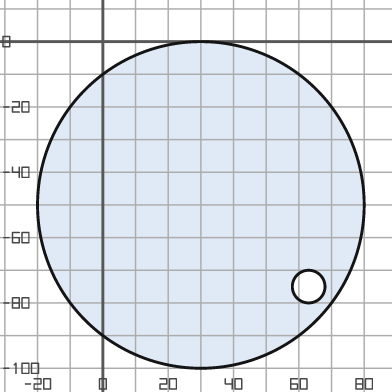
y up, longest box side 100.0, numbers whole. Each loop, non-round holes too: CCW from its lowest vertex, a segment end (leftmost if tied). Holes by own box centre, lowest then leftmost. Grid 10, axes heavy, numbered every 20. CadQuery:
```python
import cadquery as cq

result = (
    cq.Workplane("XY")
    .moveTo(30.0, -50.0)
    .circle(50.0)
    .moveTo(63.0, -75.0)
    .circle(5.0)
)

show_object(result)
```